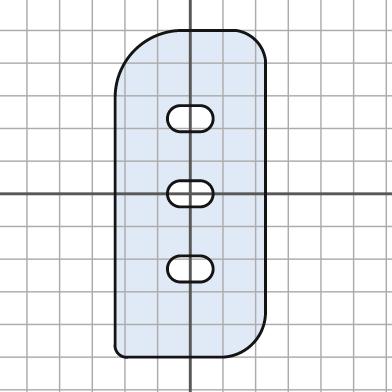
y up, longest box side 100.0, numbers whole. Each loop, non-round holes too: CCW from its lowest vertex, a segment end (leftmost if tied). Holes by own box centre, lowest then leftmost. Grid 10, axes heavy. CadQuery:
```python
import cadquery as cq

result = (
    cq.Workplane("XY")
    .moveTo(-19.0, -50.0)
    .lineTo(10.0, -50.0)
    .threePointArc((19.0, -46.0), (23.0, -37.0))
    .lineTo(23.0, 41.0)
    .threePointArc((20.0, 47.0), (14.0, 50.0))
    .lineTo(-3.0, 50.0)
    .threePointArc((-17.0, 44.0), (-23.0, 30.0))
    .lineTo(-23.0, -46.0)
    .threePointArc((-22.0, -49.0), (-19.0, -50.0))
    .close()
    .moveTo(-3.0, -27.0)
    .lineTo(3.0, -27.0)
    .threePointArc((7.0, -23.0), (3.0, -19.0))
    .lineTo(-3.0, -19.0)
    .threePointArc((-7.0, -23.0), (-3.0, -27.0))
    .close()
    .moveTo(-3.0, -4.0)
    .lineTo(3.0, -4.0)
    .threePointArc((7.0, 0.0), (3.0, 4.0))
    .lineTo(-3.0, 4.0)
    .threePointArc((-7.0, 0.0), (-3.0, -4.0))
    .close()
    .moveTo(-3.0, 19.0)
    .lineTo(3.0, 19.0)
    .threePointArc((7.0, 23.0), (3.0, 27.0))
    .lineTo(-3.0, 27.0)
    .threePointArc((-7.0, 23.0), (-3.0, 19.0))
    .close()
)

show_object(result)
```